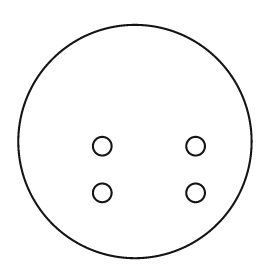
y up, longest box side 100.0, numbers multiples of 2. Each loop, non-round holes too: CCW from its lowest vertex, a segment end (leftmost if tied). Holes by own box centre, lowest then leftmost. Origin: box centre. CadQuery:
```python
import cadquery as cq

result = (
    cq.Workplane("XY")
    .moveTo(0.0, 0.0)
    .circle(50.0)
    .moveTo(-14.0, -22.0)
    .circle(4.0)
    .moveTo(26.0, -22.0)
    .circle(4.0)
    .moveTo(-14.0, -2.0)
    .circle(4.0)
    .moveTo(26.0, -2.0)
    .circle(4.0)
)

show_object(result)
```